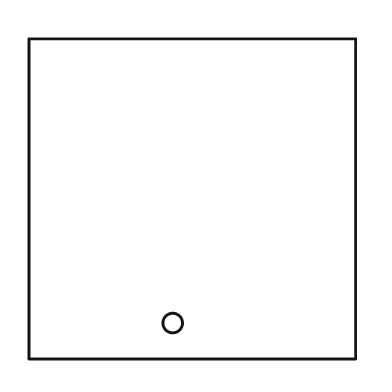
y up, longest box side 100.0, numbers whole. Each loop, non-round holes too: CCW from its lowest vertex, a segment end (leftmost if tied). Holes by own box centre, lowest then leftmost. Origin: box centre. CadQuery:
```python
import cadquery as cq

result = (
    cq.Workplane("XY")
    .moveTo(-50.0, -49.0)
    .lineTo(50.0, -49.0)
    .lineTo(50.0, 49.0)
    .lineTo(-50.0, 49.0)
    .close()
    .moveTo(-6.0, -38.0)
    .circle(3.0)
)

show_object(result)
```